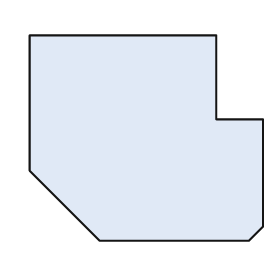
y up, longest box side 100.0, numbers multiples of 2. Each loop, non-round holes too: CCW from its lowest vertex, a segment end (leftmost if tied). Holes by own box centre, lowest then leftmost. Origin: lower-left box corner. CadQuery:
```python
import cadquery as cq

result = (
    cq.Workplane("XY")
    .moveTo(30.0, 0.0)
    .lineTo(94.0, 0.0)
    .lineTo(100.0, 6.0)
    .lineTo(100.0, 52.0)
    .lineTo(80.0, 52.0)
    .lineTo(80.0, 88.0)
    .lineTo(0.0, 88.0)
    .lineTo(0.0, 30.0)
    .close()
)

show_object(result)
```